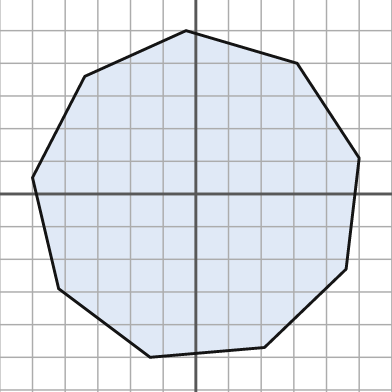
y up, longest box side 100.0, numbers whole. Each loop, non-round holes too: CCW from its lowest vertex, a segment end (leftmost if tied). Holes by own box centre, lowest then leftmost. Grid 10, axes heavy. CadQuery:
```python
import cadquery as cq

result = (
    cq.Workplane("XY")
    .moveTo(-14.0, -50.0)
    .lineTo(21.0, -47.0)
    .lineTo(46.0, -23.0)
    .lineTo(50.0, 11.0)
    .lineTo(31.0, 40.0)
    .lineTo(-3.0, 50.0)
    .lineTo(-34.0, 36.0)
    .lineTo(-50.0, 5.0)
    .lineTo(-42.0, -29.0)
    .close()
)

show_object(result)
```